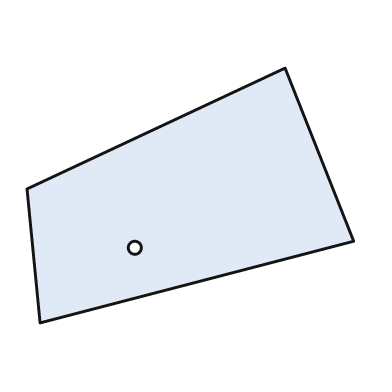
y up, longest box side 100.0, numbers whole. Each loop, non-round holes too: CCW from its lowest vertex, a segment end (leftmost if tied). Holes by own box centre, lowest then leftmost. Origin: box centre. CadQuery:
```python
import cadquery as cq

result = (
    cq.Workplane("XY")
    .moveTo(-46.0, -39.0)
    .lineTo(50.0, -14.0)
    .lineTo(29.0, 39.0)
    .lineTo(-50.0, 2.0)
    .close()
    .moveTo(-17.0, -16.0)
    .circle(2.0)
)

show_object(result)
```